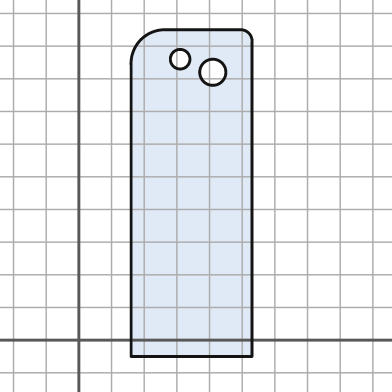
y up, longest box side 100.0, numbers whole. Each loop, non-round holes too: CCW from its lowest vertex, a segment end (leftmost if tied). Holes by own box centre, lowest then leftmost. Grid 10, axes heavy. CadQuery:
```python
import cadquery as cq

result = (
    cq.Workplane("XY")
    .moveTo(16.0, -5.0)
    .lineTo(53.0, -5.0)
    .lineTo(53.0, 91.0)
    .threePointArc((52.0, 94.0), (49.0, 95.0))
    .lineTo(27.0, 95.0)
    .threePointArc((19.0, 92.0), (16.0, 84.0))
    .close()
    .moveTo(41.0, 82.0)
    .circle(4.0)
    .moveTo(31.0, 86.0)
    .circle(3.0)
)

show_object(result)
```